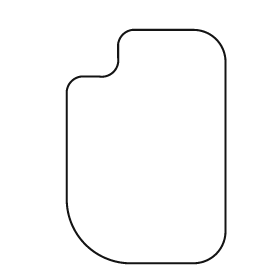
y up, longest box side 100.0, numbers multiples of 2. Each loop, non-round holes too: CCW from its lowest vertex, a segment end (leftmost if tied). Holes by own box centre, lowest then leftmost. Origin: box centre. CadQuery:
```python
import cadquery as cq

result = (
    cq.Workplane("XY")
    .moveTo(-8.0, -50.0)
    .lineTo(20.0, -50.0)
    .threePointArc((30.0, -46.0), (34.0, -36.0))
    .lineTo(34.0, 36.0)
    .threePointArc((30.0, 46.0), (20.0, 50.0))
    .lineTo(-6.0, 50.0)
    .threePointArc((-10.0, 48.0), (-12.0, 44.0))
    .lineTo(-12.0, 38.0)
    .threePointArc((-14.0, 32.0), (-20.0, 30.0))
    .lineTo(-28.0, 30.0)
    .threePointArc((-32.0, 28.0), (-34.0, 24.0))
    .lineTo(-34.0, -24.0)
    .threePointArc((-26.0, -42.0), (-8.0, -50.0))
    .close()
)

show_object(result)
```